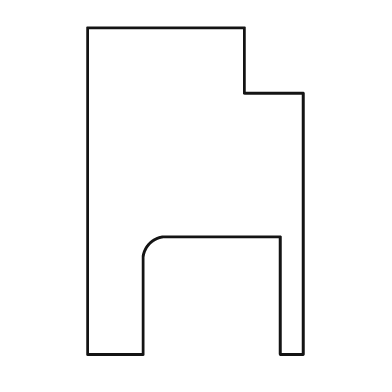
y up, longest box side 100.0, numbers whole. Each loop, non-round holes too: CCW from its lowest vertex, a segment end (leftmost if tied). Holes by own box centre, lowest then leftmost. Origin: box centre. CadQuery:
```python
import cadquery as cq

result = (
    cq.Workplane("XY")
    .moveTo(-33.0, -50.0)
    .lineTo(-16.0, -50.0)
    .lineTo(-16.0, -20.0)
    .threePointArc((-14.0, -16.0), (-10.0, -14.0))
    .lineTo(26.0, -14.0)
    .lineTo(26.0, -50.0)
    .lineTo(33.0, -50.0)
    .lineTo(33.0, 30.0)
    .lineTo(15.0, 30.0)
    .lineTo(15.0, 50.0)
    .lineTo(-33.0, 50.0)
    .close()
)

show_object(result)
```